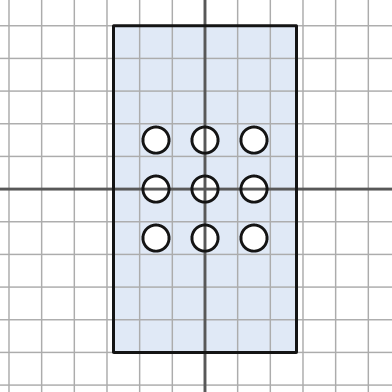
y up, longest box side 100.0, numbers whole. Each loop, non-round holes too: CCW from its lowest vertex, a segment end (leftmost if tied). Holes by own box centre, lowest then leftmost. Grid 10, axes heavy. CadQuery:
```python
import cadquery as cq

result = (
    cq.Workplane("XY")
    .moveTo(-28.0, -50.0)
    .lineTo(28.0, -50.0)
    .lineTo(28.0, 50.0)
    .lineTo(-28.0, 50.0)
    .close()
    .moveTo(-15.0, -15.0)
    .circle(4.0)
    .moveTo(0.0, -15.0)
    .circle(4.0)
    .moveTo(15.0, -15.0)
    .circle(4.0)
    .moveTo(-15.0, 0.0)
    .circle(4.0)
    .moveTo(0.0, 0.0)
    .circle(4.0)
    .moveTo(15.0, 0.0)
    .circle(4.0)
    .moveTo(-15.0, 15.0)
    .circle(4.0)
    .moveTo(0.0, 15.0)
    .circle(4.0)
    .moveTo(15.0, 15.0)
    .circle(4.0)
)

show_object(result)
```